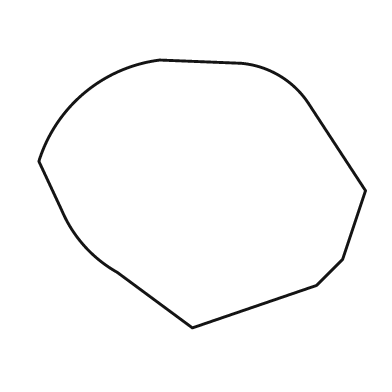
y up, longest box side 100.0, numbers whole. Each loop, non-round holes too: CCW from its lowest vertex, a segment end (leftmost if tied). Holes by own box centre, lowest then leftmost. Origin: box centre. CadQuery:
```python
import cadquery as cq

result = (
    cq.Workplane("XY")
    .moveTo(-3.0, -41.0)
    .lineTo(35.0, -28.0)
    .lineTo(43.0, -20.0)
    .lineTo(50.0, 1.0)
    .lineTo(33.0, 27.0)
    .threePointArc((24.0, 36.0), (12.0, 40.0))
    .lineTo(-13.0, 41.0)
    .threePointArc((-36.0, 31.0), (-50.0, 10.0))
    .lineTo(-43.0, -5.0)
    .threePointArc((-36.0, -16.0), (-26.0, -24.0))
    .close()
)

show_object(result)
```